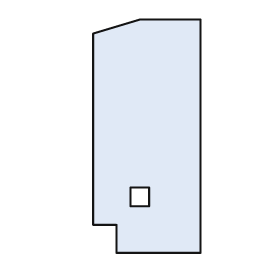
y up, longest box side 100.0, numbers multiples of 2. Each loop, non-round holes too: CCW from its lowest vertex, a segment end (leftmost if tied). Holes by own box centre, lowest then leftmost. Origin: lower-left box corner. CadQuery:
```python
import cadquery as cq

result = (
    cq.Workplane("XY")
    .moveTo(10.0, 0.0)
    .lineTo(46.0, 0.0)
    .lineTo(46.0, 100.0)
    .lineTo(20.0, 100.0)
    .lineTo(0.0, 94.0)
    .lineTo(0.0, 12.0)
    .lineTo(10.0, 12.0)
    .close()
    .moveTo(16.0, 20.0)
    .lineTo(24.0, 20.0)
    .lineTo(24.0, 28.0)
    .lineTo(16.0, 28.0)
    .close()
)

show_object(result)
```